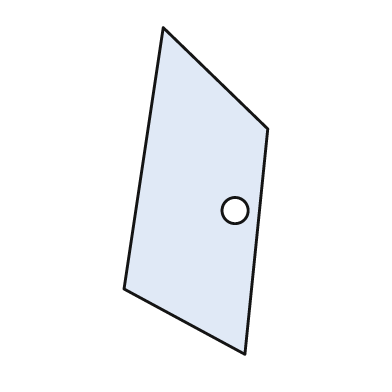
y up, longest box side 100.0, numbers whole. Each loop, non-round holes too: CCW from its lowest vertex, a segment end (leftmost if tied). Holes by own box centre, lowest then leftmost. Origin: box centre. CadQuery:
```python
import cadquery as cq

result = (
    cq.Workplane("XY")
    .moveTo(15.0, -50.0)
    .lineTo(22.0, 19.0)
    .lineTo(-10.0, 50.0)
    .lineTo(-22.0, -30.0)
    .close()
    .moveTo(12.0, -6.0)
    .circle(4.0)
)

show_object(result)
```